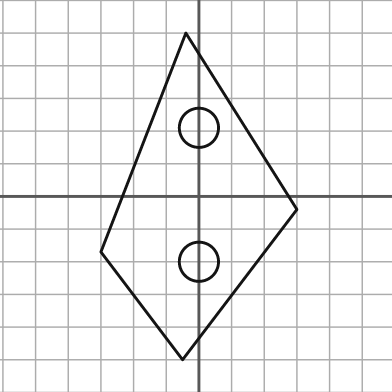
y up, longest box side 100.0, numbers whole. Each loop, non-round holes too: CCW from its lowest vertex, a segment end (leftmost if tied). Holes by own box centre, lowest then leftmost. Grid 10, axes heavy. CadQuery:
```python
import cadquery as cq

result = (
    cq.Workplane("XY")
    .moveTo(-5.0, -50.0)
    .lineTo(30.0, -4.0)
    .lineTo(-4.0, 50.0)
    .lineTo(-30.0, -17.0)
    .close()
    .moveTo(0.0, -20.0)
    .circle(6.0)
    .moveTo(0.0, 21.0)
    .circle(6.0)
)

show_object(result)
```